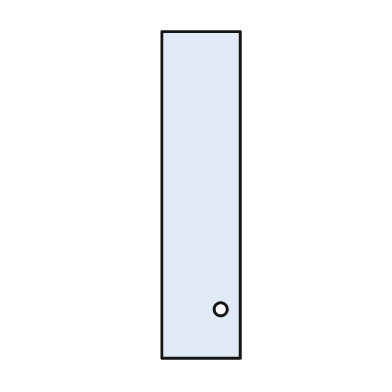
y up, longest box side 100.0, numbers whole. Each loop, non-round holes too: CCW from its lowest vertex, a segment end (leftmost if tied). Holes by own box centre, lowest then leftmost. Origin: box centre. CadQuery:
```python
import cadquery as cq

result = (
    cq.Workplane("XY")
    .moveTo(-12.0, -50.0)
    .lineTo(12.0, -50.0)
    .lineTo(12.0, 50.0)
    .lineTo(-12.0, 50.0)
    .close()
    .moveTo(6.0, -35.0)
    .circle(2.0)
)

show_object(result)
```